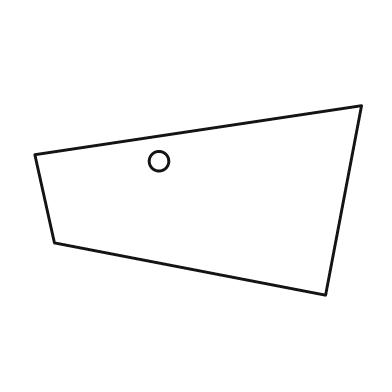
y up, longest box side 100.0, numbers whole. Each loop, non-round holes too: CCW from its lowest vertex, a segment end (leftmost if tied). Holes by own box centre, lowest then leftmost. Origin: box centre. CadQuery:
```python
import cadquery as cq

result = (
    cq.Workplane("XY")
    .moveTo(39.0, -29.0)
    .lineTo(50.0, 29.0)
    .lineTo(-50.0, 14.0)
    .lineTo(-44.0, -13.0)
    .close()
    .moveTo(-12.0, 12.0)
    .circle(3.0)
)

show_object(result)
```